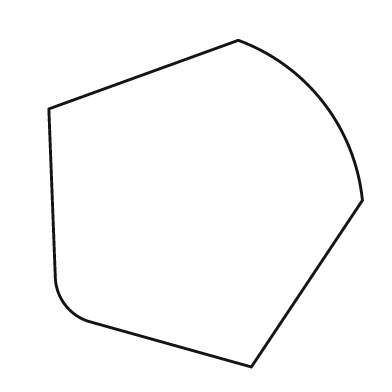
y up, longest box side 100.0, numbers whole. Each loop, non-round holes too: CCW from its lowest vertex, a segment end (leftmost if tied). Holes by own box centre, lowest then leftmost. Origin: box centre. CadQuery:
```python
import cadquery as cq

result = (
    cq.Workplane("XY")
    .moveTo(14.0, -50.0)
    .lineTo(48.0, 1.0)
    .threePointArc((36.0, 31.0), (10.0, 50.0))
    .lineTo(-48.0, 29.0)
    .lineTo(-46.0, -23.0)
    .threePointArc((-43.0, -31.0), (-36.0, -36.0))
    .close()
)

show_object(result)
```